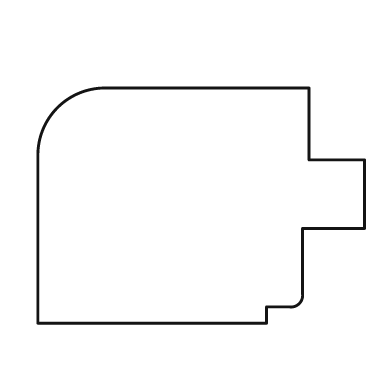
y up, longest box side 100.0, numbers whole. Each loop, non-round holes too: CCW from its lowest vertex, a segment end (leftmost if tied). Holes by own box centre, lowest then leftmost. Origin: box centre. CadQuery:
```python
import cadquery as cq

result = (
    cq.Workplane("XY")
    .moveTo(-50.0, -36.0)
    .lineTo(20.0, -36.0)
    .lineTo(20.0, -31.0)
    .lineTo(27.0, -31.0)
    .threePointArc((30.0, -30.0), (31.0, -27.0))
    .lineTo(31.0, -7.0)
    .lineTo(50.0, -7.0)
    .lineTo(50.0, 14.0)
    .lineTo(33.0, 14.0)
    .lineTo(33.0, 36.0)
    .lineTo(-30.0, 36.0)
    .threePointArc((-44.0, 30.0), (-50.0, 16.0))
    .close()
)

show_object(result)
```